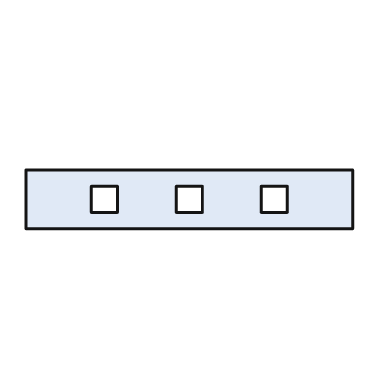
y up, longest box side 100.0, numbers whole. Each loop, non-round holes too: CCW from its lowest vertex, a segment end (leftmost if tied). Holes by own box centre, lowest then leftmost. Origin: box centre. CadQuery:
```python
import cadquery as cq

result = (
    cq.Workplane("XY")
    .moveTo(-50.0, -9.0)
    .lineTo(50.0, -9.0)
    .lineTo(50.0, 9.0)
    .lineTo(-50.0, 9.0)
    .close()
    .moveTo(-30.0, -4.0)
    .lineTo(-22.0, -4.0)
    .lineTo(-22.0, 4.0)
    .lineTo(-30.0, 4.0)
    .close()
    .moveTo(-4.0, -4.0)
    .lineTo(4.0, -4.0)
    .lineTo(4.0, 4.0)
    .lineTo(-4.0, 4.0)
    .close()
    .moveTo(22.0, -4.0)
    .lineTo(30.0, -4.0)
    .lineTo(30.0, 4.0)
    .lineTo(22.0, 4.0)
    .close()
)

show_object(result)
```